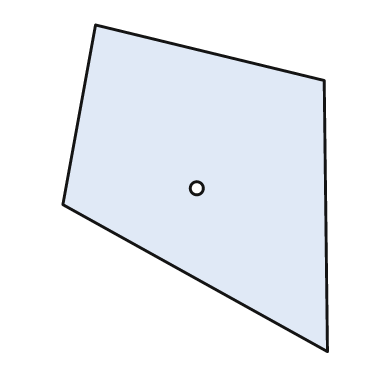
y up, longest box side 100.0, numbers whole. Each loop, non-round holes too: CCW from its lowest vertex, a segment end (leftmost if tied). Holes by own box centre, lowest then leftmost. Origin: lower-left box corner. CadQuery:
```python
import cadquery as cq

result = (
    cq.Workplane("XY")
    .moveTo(81.0, 0.0)
    .lineTo(80.0, 83.0)
    .lineTo(10.0, 100.0)
    .lineTo(0.0, 45.0)
    .close()
    .moveTo(41.0, 50.0)
    .circle(2.0)
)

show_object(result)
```